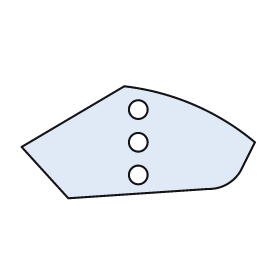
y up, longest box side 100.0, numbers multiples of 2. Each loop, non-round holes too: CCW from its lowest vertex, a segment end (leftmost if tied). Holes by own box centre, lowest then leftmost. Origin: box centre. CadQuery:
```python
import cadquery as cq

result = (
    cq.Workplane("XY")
    .moveTo(-30.0, -24.0)
    .lineTo(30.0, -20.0)
    .threePointArc((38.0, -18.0), (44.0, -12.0))
    .lineTo(50.0, 0.0)
    .threePointArc((24.0, 16.0), (-6.0, 24.0))
    .lineTo(-50.0, -2.0)
    .close()
    .moveTo(0.0, -14.0)
    .circle(4.0)
    .moveTo(0.0, 0.0)
    .circle(4.0)
    .moveTo(0.0, 14.0)
    .circle(4.0)
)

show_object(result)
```